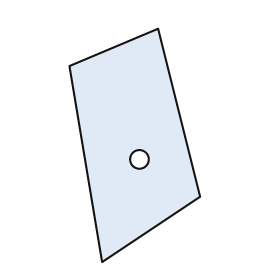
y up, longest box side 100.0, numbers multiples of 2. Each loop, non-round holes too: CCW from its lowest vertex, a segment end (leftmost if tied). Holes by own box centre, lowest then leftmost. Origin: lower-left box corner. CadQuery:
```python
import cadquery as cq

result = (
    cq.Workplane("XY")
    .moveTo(14.0, 0.0)
    .lineTo(56.0, 28.0)
    .lineTo(38.0, 100.0)
    .lineTo(0.0, 84.0)
    .close()
    .moveTo(30.0, 44.0)
    .circle(4.0)
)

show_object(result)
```